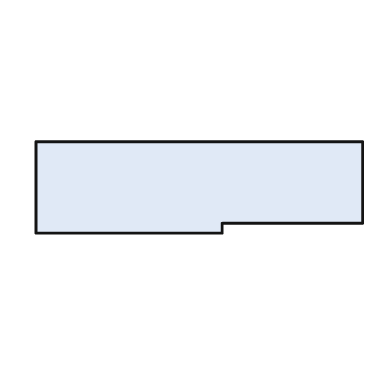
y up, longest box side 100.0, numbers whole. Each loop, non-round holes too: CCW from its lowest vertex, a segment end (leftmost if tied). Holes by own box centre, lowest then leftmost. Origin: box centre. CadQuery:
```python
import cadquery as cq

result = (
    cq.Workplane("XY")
    .moveTo(-50.0, -14.0)
    .lineTo(7.0, -14.0)
    .lineTo(7.0, -11.0)
    .lineTo(50.0, -11.0)
    .lineTo(50.0, 14.0)
    .lineTo(-50.0, 14.0)
    .close()
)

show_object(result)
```